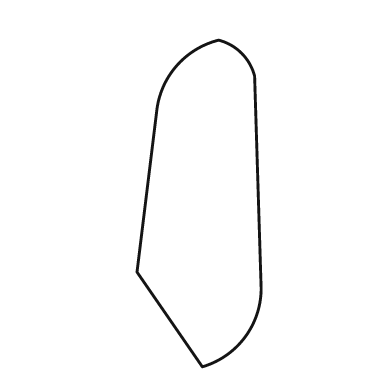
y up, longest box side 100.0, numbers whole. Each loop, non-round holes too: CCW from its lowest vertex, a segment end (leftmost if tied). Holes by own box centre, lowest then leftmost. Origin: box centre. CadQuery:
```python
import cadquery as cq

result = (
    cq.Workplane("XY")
    .moveTo(1.0, -50.0)
    .threePointArc((14.0, -41.0), (19.0, -26.0))
    .lineTo(17.0, 39.0)
    .threePointArc((13.0, 46.0), (6.0, 50.0))
    .threePointArc((-7.0, 42.0), (-13.0, 28.0))
    .lineTo(-19.0, -21.0)
    .close()
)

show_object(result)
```